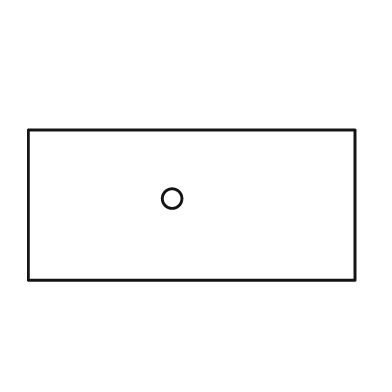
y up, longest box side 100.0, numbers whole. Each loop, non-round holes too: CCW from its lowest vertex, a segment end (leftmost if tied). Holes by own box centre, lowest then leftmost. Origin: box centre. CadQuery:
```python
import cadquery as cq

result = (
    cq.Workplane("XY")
    .moveTo(-50.0, -23.0)
    .lineTo(50.0, -23.0)
    .lineTo(50.0, 23.0)
    .lineTo(-50.0, 23.0)
    .close()
    .moveTo(-6.0, 2.0)
    .circle(3.0)
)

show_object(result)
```